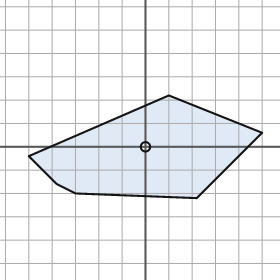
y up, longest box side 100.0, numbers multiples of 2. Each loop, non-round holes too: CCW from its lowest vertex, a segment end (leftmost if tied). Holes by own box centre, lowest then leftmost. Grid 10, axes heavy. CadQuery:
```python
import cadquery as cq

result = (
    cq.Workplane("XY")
    .moveTo(22.0, -22.0)
    .lineTo(50.0, 6.0)
    .lineTo(10.0, 22.0)
    .lineTo(-50.0, -4.0)
    .lineTo(-38.0, -16.0)
    .lineTo(-30.0, -20.0)
    .close()
    .moveTo(0.0, 0.0)
    .circle(2.0)
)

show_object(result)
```